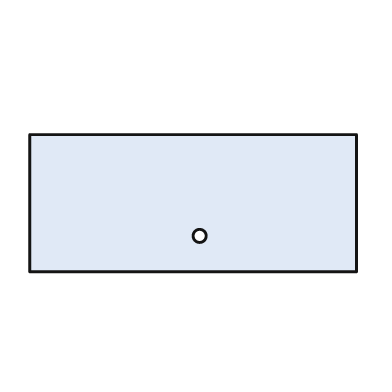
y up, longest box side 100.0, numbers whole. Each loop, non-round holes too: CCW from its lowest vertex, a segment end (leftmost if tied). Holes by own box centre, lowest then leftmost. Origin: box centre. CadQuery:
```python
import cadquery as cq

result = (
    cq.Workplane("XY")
    .moveTo(-50.0, -21.0)
    .lineTo(50.0, -21.0)
    .lineTo(50.0, 21.0)
    .lineTo(-50.0, 21.0)
    .close()
    .moveTo(2.0, -10.0)
    .circle(2.0)
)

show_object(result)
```